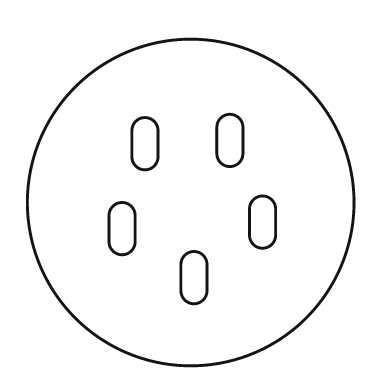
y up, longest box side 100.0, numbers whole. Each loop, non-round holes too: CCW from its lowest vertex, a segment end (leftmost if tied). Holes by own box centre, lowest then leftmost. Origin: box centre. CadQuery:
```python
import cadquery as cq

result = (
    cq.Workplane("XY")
    .moveTo(0.0, 0.0)
    .circle(50.0)
    .moveTo(-3.0, -27.0)
    .threePointArc((1.0, -31.0), (5.0, -27.0))
    .lineTo(5.0, -19.0)
    .threePointArc((1.0, -15.0), (-3.0, -19.0))
    .close()
    .moveTo(-25.0, -12.0)
    .threePointArc((-21.0, -16.0), (-17.0, -12.0))
    .lineTo(-17.0, -4.0)
    .threePointArc((-21.0, 0.0), (-25.0, -4.0))
    .close()
    .moveTo(18.0, -10.0)
    .threePointArc((22.0, -14.0), (26.0, -10.0))
    .lineTo(26.0, -2.0)
    .threePointArc((22.0, 2.0), (18.0, -2.0))
    .close()
    .moveTo(-18.0, 14.0)
    .threePointArc((-14.0, 10.0), (-10.0, 14.0))
    .lineTo(-10.0, 22.0)
    .threePointArc((-14.0, 26.0), (-18.0, 22.0))
    .close()
    .moveTo(8.0, 15.0)
    .threePointArc((12.0, 11.0), (16.0, 15.0))
    .lineTo(16.0, 23.0)
    .threePointArc((12.0, 27.0), (8.0, 23.0))
    .close()
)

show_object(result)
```